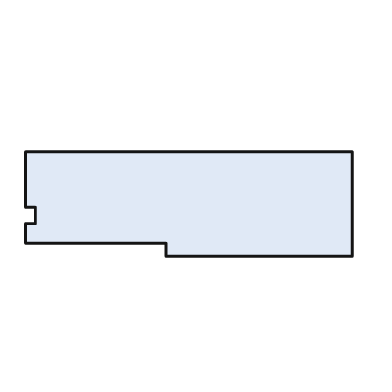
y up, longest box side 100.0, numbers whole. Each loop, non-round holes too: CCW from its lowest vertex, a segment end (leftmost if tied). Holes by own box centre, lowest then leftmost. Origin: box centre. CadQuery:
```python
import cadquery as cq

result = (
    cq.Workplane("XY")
    .moveTo(-7.0, -16.0)
    .lineTo(50.0, -16.0)
    .lineTo(50.0, 16.0)
    .lineTo(-50.0, 16.0)
    .lineTo(-50.0, -1.0)
    .lineTo(-47.0, -1.0)
    .lineTo(-47.0, -6.0)
    .lineTo(-50.0, -6.0)
    .lineTo(-50.0, -12.0)
    .lineTo(-7.0, -12.0)
    .close()
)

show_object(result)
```